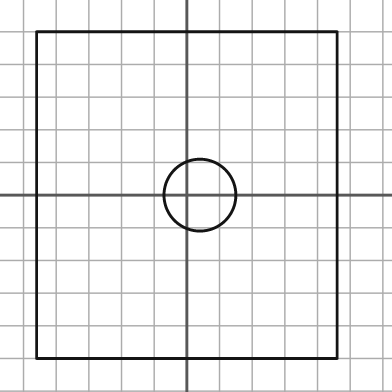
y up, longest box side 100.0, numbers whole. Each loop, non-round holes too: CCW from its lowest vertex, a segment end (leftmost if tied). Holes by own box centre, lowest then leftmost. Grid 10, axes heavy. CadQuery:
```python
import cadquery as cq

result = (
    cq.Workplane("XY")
    .moveTo(-46.0, -50.0)
    .lineTo(46.0, -50.0)
    .lineTo(46.0, 50.0)
    .lineTo(-46.0, 50.0)
    .close()
    .moveTo(4.0, 0.0)
    .circle(11.0)
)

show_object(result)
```